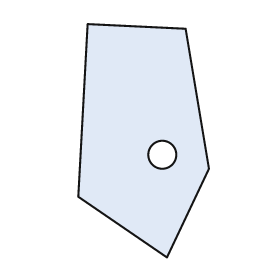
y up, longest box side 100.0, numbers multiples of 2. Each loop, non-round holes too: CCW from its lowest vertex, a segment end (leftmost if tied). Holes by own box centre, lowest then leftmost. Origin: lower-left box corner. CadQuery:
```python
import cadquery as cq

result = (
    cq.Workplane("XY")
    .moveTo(38.0, 0.0)
    .lineTo(56.0, 38.0)
    .lineTo(46.0, 98.0)
    .lineTo(4.0, 100.0)
    .lineTo(0.0, 26.0)
    .close()
    .moveTo(36.0, 44.0)
    .circle(6.0)
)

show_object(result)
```